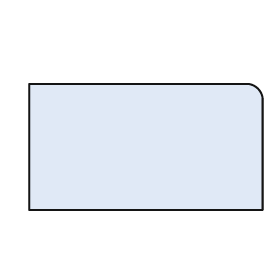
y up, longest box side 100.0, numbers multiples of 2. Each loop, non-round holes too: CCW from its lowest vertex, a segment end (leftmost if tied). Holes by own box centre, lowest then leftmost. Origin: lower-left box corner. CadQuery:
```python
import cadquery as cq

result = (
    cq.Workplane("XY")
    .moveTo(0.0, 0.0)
    .lineTo(100.0, 0.0)
    .lineTo(100.0, 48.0)
    .threePointArc((98.0, 52.0), (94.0, 54.0))
    .lineTo(0.0, 54.0)
    .close()
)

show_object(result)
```